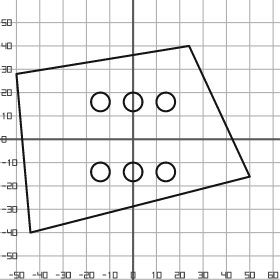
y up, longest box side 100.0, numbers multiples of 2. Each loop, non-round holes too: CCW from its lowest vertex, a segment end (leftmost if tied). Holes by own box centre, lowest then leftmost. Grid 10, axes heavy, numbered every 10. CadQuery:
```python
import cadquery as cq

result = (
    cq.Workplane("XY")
    .moveTo(-44.0, -40.0)
    .lineTo(50.0, -16.0)
    .lineTo(24.0, 40.0)
    .lineTo(-50.0, 28.0)
    .close()
    .moveTo(-14.0, -14.0)
    .circle(4.0)
    .moveTo(0.0, -14.0)
    .circle(4.0)
    .moveTo(14.0, -14.0)
    .circle(4.0)
    .moveTo(-14.0, 16.0)
    .circle(4.0)
    .moveTo(0.0, 16.0)
    .circle(4.0)
    .moveTo(14.0, 16.0)
    .circle(4.0)
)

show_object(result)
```